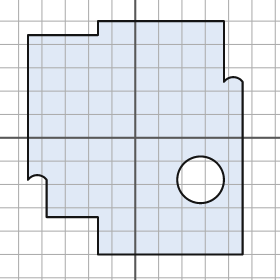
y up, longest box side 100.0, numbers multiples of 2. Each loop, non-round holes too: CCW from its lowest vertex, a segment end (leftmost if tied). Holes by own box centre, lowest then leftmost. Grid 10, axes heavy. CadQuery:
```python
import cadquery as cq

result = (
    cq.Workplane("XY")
    .moveTo(-16.0, -50.0)
    .lineTo(46.0, -50.0)
    .lineTo(46.0, 24.0)
    .threePointArc((42.0, 26.0), (38.0, 24.0))
    .lineTo(38.0, 50.0)
    .lineTo(-16.0, 50.0)
    .lineTo(-16.0, 44.0)
    .lineTo(-46.0, 44.0)
    .lineTo(-46.0, -18.0)
    .threePointArc((-42.0, -16.0), (-38.0, -18.0))
    .lineTo(-38.0, -34.0)
    .lineTo(-16.0, -34.0)
    .close()
    .moveTo(28.0, -18.0)
    .circle(10.0)
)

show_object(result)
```